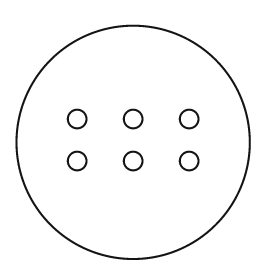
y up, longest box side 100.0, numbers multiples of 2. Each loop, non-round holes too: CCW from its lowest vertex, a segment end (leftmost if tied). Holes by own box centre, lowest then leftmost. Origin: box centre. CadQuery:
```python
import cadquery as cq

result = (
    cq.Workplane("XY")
    .moveTo(0.0, 0.0)
    .circle(50.0)
    .moveTo(-24.0, -8.0)
    .circle(4.0)
    .moveTo(0.0, -8.0)
    .circle(4.0)
    .moveTo(24.0, -8.0)
    .circle(4.0)
    .moveTo(-24.0, 10.0)
    .circle(4.0)
    .moveTo(0.0, 10.0)
    .circle(4.0)
    .moveTo(24.0, 10.0)
    .circle(4.0)
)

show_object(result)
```